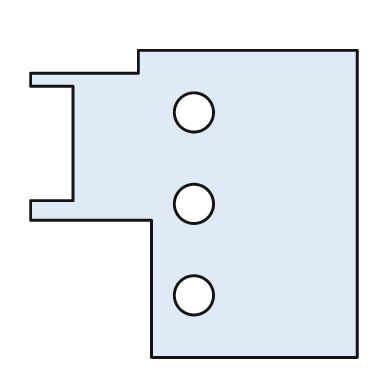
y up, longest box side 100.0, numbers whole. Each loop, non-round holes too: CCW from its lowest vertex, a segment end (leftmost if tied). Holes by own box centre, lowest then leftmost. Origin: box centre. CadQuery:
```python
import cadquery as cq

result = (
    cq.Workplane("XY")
    .moveTo(-13.0, -47.0)
    .lineTo(50.0, -47.0)
    .lineTo(50.0, 47.0)
    .lineTo(-17.0, 47.0)
    .lineTo(-17.0, 40.0)
    .lineTo(-50.0, 40.0)
    .lineTo(-50.0, 36.0)
    .lineTo(-37.0, 36.0)
    .lineTo(-37.0, 1.0)
    .lineTo(-50.0, 1.0)
    .lineTo(-50.0, -5.0)
    .lineTo(-13.0, -5.0)
    .close()
    .moveTo(0.0, -28.0)
    .circle(6.0)
    .moveTo(0.0, 0.0)
    .circle(6.0)
    .moveTo(0.0, 28.0)
    .circle(6.0)
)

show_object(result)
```